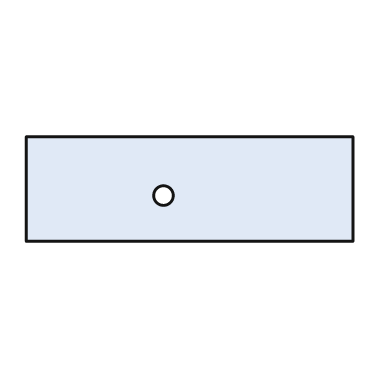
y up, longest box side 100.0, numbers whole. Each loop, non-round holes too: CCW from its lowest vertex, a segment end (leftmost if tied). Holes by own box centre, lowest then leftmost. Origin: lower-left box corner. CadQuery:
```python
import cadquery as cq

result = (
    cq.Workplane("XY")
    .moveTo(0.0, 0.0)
    .lineTo(100.0, 0.0)
    .lineTo(100.0, 32.0)
    .lineTo(0.0, 32.0)
    .close()
    .moveTo(42.0, 14.0)
    .circle(3.0)
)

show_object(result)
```